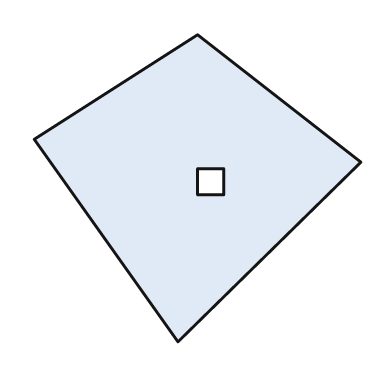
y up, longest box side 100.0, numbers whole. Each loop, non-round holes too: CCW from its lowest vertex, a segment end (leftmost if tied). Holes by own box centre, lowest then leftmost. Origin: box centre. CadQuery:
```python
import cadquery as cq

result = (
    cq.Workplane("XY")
    .moveTo(-6.0, -47.0)
    .lineTo(50.0, 8.0)
    .lineTo(0.0, 47.0)
    .lineTo(-50.0, 15.0)
    .close()
    .moveTo(0.0, -2.0)
    .lineTo(8.0, -2.0)
    .lineTo(8.0, 6.0)
    .lineTo(0.0, 6.0)
    .close()
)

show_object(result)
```